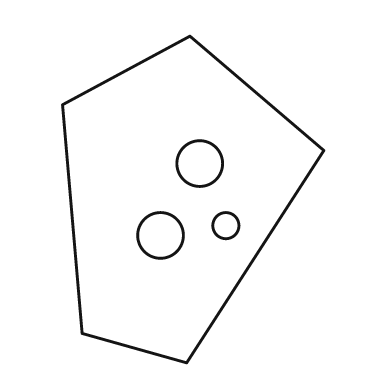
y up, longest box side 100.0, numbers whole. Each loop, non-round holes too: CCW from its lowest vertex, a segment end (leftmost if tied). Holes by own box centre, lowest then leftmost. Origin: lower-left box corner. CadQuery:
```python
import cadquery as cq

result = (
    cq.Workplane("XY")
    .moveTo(38.0, 0.0)
    .lineTo(80.0, 65.0)
    .lineTo(39.0, 100.0)
    .lineTo(0.0, 79.0)
    .lineTo(6.0, 9.0)
    .close()
    .moveTo(30.0, 39.0)
    .circle(7.0)
    .moveTo(50.0, 42.0)
    .circle(4.0)
    .moveTo(42.0, 61.0)
    .circle(7.0)
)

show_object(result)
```